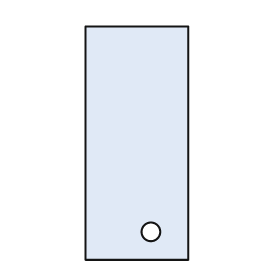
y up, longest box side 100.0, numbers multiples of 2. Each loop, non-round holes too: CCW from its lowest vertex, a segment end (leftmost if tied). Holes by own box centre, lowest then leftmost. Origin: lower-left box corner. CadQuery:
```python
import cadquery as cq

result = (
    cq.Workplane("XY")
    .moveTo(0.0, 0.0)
    .lineTo(44.0, 0.0)
    .lineTo(44.0, 100.0)
    .lineTo(0.0, 100.0)
    .close()
    .moveTo(28.0, 12.0)
    .circle(4.0)
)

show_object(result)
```